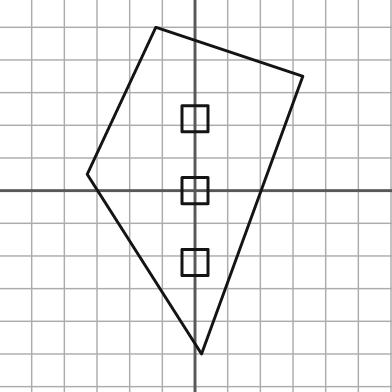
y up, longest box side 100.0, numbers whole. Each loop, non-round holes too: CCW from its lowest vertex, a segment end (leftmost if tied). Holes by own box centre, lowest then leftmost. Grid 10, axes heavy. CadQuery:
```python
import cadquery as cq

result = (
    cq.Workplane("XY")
    .moveTo(2.0, -50.0)
    .lineTo(33.0, 35.0)
    .lineTo(-12.0, 50.0)
    .lineTo(-33.0, 5.0)
    .close()
    .moveTo(-4.0, -26.0)
    .lineTo(4.0, -26.0)
    .lineTo(4.0, -18.0)
    .lineTo(-4.0, -18.0)
    .close()
    .moveTo(-4.0, -4.0)
    .lineTo(4.0, -4.0)
    .lineTo(4.0, 4.0)
    .lineTo(-4.0, 4.0)
    .close()
    .moveTo(-4.0, 18.0)
    .lineTo(4.0, 18.0)
    .lineTo(4.0, 26.0)
    .lineTo(-4.0, 26.0)
    .close()
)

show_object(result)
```